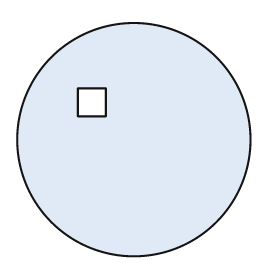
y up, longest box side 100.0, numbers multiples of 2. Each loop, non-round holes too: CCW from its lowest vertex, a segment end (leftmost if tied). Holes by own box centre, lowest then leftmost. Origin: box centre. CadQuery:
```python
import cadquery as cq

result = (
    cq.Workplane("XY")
    .moveTo(0.0, 0.0)
    .circle(50.0)
    .moveTo(-24.0, 10.0)
    .lineTo(-12.0, 10.0)
    .lineTo(-12.0, 22.0)
    .lineTo(-24.0, 22.0)
    .close()
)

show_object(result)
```